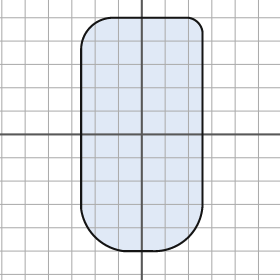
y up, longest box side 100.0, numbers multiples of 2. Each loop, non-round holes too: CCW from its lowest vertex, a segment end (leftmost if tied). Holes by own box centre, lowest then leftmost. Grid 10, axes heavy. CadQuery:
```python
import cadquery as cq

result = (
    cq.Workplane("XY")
    .moveTo(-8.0, -50.0)
    .lineTo(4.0, -50.0)
    .threePointArc((20.0, -44.0), (26.0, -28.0))
    .lineTo(26.0, 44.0)
    .threePointArc((24.0, 48.0), (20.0, 50.0))
    .lineTo(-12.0, 50.0)
    .threePointArc((-22.0, 46.0), (-26.0, 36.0))
    .lineTo(-26.0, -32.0)
    .threePointArc((-20.0, -44.0), (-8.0, -50.0))
    .close()
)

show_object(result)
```